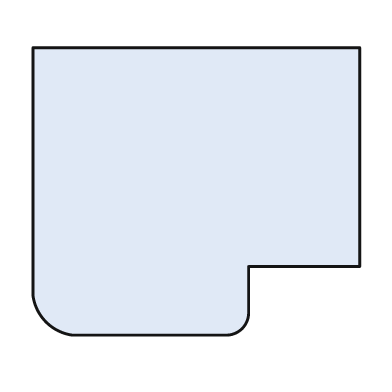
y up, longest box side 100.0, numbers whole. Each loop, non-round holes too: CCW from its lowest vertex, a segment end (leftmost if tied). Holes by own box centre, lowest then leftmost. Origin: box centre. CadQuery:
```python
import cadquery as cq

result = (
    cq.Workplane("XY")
    .moveTo(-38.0, -44.0)
    .lineTo(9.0, -44.0)
    .threePointArc((14.0, -42.0), (16.0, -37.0))
    .lineTo(16.0, -23.0)
    .lineTo(50.0, -23.0)
    .lineTo(50.0, 44.0)
    .lineTo(-50.0, 44.0)
    .lineTo(-50.0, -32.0)
    .threePointArc((-46.0, -40.0), (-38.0, -44.0))
    .close()
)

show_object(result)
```